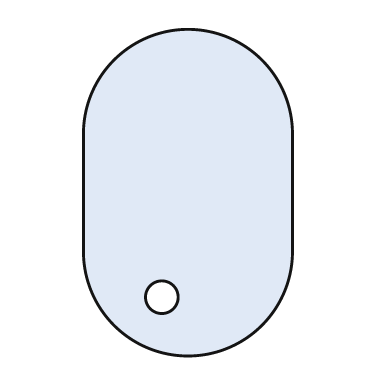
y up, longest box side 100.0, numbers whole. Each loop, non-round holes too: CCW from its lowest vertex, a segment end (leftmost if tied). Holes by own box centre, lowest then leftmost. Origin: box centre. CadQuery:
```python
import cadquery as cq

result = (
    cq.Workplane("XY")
    .moveTo(-32.0, -18.0)
    .threePointArc((0.0, -50.0), (32.0, -18.0))
    .lineTo(32.0, 18.0)
    .threePointArc((0.0, 50.0), (-32.0, 18.0))
    .close()
    .moveTo(-8.0, -32.0)
    .circle(5.0)
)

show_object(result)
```